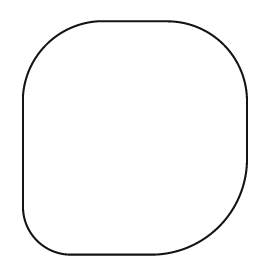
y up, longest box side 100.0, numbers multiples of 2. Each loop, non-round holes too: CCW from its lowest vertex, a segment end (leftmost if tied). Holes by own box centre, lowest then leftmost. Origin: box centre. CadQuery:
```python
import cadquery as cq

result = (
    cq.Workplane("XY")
    .moveTo(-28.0, -50.0)
    .lineTo(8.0, -50.0)
    .threePointArc((36.0, -38.0), (48.0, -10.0))
    .lineTo(48.0, 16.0)
    .threePointArc((38.0, 40.0), (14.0, 50.0))
    .lineTo(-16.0, 50.0)
    .threePointArc((-38.0, 40.0), (-48.0, 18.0))
    .lineTo(-48.0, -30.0)
    .threePointArc((-42.0, -44.0), (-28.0, -50.0))
    .close()
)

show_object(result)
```